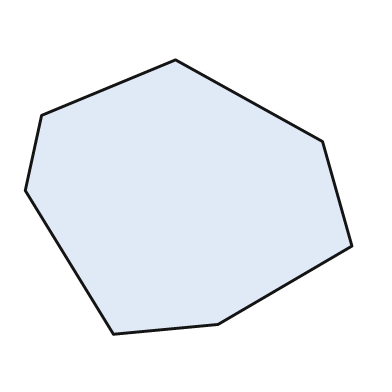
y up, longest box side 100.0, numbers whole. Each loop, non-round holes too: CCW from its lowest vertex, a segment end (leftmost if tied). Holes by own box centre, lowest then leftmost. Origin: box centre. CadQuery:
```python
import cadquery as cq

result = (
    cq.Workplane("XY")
    .moveTo(-23.0, -42.0)
    .lineTo(9.0, -39.0)
    .lineTo(50.0, -15.0)
    .lineTo(41.0, 17.0)
    .lineTo(-4.0, 42.0)
    .lineTo(-45.0, 25.0)
    .lineTo(-50.0, 2.0)
    .close()
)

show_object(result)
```